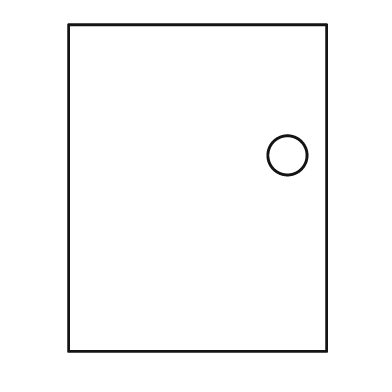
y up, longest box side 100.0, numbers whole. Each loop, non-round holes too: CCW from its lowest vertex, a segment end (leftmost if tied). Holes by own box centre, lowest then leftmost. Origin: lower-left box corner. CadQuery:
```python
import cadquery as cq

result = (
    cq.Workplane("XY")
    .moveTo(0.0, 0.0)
    .lineTo(79.0, 0.0)
    .lineTo(79.0, 100.0)
    .lineTo(0.0, 100.0)
    .close()
    .moveTo(67.0, 60.0)
    .circle(6.0)
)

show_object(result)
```